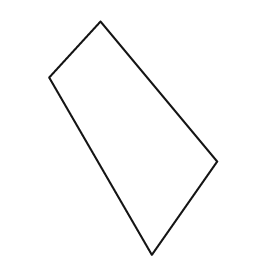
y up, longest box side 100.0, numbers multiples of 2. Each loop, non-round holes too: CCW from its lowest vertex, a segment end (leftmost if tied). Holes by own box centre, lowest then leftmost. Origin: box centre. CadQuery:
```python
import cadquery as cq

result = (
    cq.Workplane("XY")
    .moveTo(8.0, -50.0)
    .lineTo(36.0, -10.0)
    .lineTo(-14.0, 50.0)
    .lineTo(-36.0, 26.0)
    .close()
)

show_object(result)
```